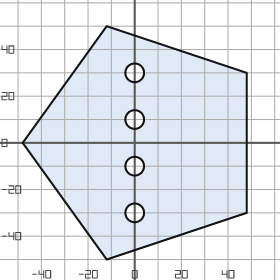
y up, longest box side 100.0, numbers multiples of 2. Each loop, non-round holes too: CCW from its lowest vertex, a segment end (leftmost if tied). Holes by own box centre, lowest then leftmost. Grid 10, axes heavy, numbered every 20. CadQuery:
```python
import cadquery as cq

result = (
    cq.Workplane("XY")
    .moveTo(-12.0, -50.0)
    .lineTo(48.0, -30.0)
    .lineTo(48.0, 30.0)
    .lineTo(-12.0, 50.0)
    .lineTo(-48.0, 0.0)
    .close()
    .moveTo(0.0, -30.0)
    .circle(4.0)
    .moveTo(0.0, -10.0)
    .circle(4.0)
    .moveTo(0.0, 10.0)
    .circle(4.0)
    .moveTo(0.0, 30.0)
    .circle(4.0)
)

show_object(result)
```